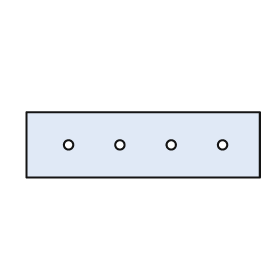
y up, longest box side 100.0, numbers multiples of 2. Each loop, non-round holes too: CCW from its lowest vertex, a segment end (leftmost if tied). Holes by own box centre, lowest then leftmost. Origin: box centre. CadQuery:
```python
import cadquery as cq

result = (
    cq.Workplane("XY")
    .moveTo(-50.0, -14.0)
    .lineTo(50.0, -14.0)
    .lineTo(50.0, 14.0)
    .lineTo(-50.0, 14.0)
    .close()
    .moveTo(-32.0, 0.0)
    .circle(2.0)
    .moveTo(-10.0, 0.0)
    .circle(2.0)
    .moveTo(12.0, 0.0)
    .circle(2.0)
    .moveTo(34.0, 0.0)
    .circle(2.0)
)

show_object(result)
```